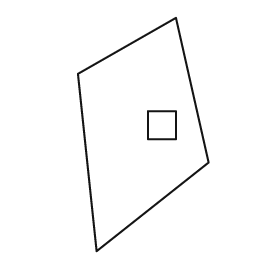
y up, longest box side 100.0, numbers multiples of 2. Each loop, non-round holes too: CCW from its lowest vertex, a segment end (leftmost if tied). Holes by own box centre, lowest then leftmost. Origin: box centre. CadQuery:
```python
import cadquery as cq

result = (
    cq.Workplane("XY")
    .moveTo(-20.0, -50.0)
    .lineTo(28.0, -12.0)
    .lineTo(14.0, 50.0)
    .lineTo(-28.0, 26.0)
    .close()
    .moveTo(2.0, -2.0)
    .lineTo(14.0, -2.0)
    .lineTo(14.0, 10.0)
    .lineTo(2.0, 10.0)
    .close()
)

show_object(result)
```